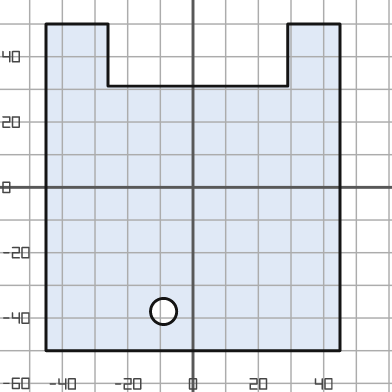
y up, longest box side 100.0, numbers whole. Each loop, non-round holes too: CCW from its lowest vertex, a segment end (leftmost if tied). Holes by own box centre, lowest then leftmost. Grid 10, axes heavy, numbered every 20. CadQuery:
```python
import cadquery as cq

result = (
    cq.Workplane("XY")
    .moveTo(-45.0, -50.0)
    .lineTo(45.0, -50.0)
    .lineTo(45.0, 50.0)
    .lineTo(29.0, 50.0)
    .lineTo(29.0, 31.0)
    .lineTo(-26.0, 31.0)
    .lineTo(-26.0, 50.0)
    .lineTo(-45.0, 50.0)
    .close()
    .moveTo(-9.0, -38.0)
    .circle(4.0)
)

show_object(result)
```